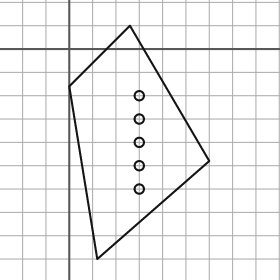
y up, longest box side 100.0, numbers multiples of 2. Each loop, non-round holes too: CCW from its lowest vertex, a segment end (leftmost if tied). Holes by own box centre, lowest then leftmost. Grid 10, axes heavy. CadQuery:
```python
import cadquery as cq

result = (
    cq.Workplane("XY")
    .moveTo(12.0, -90.0)
    .lineTo(60.0, -48.0)
    .lineTo(26.0, 10.0)
    .lineTo(0.0, -16.0)
    .close()
    .moveTo(30.0, -60.0)
    .circle(2.0)
    .moveTo(30.0, -50.0)
    .circle(2.0)
    .moveTo(30.0, -40.0)
    .circle(2.0)
    .moveTo(30.0, -30.0)
    .circle(2.0)
    .moveTo(30.0, -20.0)
    .circle(2.0)
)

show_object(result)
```